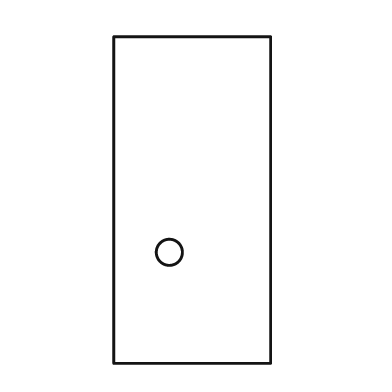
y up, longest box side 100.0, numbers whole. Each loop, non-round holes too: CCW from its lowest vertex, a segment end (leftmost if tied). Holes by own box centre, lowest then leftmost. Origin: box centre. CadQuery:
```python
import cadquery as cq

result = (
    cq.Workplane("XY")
    .moveTo(-24.0, -50.0)
    .lineTo(24.0, -50.0)
    .lineTo(24.0, 50.0)
    .lineTo(-24.0, 50.0)
    .close()
    .moveTo(-7.0, -16.0)
    .circle(4.0)
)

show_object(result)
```